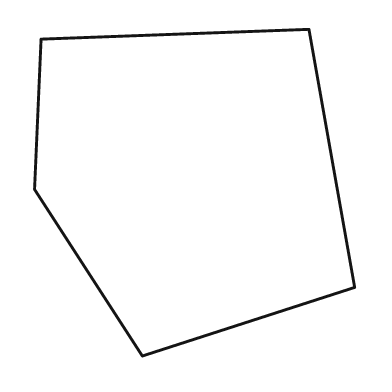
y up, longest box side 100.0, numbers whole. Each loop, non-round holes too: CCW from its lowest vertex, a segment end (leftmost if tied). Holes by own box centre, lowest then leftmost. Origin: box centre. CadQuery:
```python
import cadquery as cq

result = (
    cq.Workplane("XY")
    .moveTo(-16.0, -50.0)
    .lineTo(49.0, -29.0)
    .lineTo(35.0, 50.0)
    .lineTo(-47.0, 47.0)
    .lineTo(-49.0, 1.0)
    .close()
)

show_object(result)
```